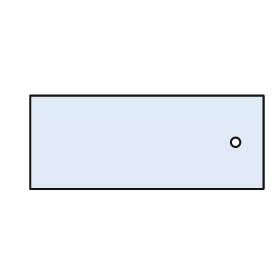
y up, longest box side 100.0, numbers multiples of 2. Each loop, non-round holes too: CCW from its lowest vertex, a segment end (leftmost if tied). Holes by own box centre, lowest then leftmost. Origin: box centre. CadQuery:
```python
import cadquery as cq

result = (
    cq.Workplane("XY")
    .moveTo(-50.0, -20.0)
    .lineTo(50.0, -20.0)
    .lineTo(50.0, 20.0)
    .lineTo(-50.0, 20.0)
    .close()
    .moveTo(38.0, 0.0)
    .circle(2.0)
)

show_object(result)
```